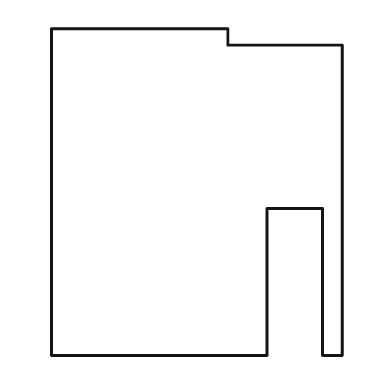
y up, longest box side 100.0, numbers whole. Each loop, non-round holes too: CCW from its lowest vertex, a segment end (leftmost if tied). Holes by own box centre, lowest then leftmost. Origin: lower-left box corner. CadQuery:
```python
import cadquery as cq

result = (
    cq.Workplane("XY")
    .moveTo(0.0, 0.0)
    .lineTo(66.0, 0.0)
    .lineTo(66.0, 45.0)
    .lineTo(83.0, 45.0)
    .lineTo(83.0, 0.0)
    .lineTo(89.0, 0.0)
    .lineTo(89.0, 95.0)
    .lineTo(54.0, 95.0)
    .lineTo(54.0, 100.0)
    .lineTo(0.0, 100.0)
    .close()
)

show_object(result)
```